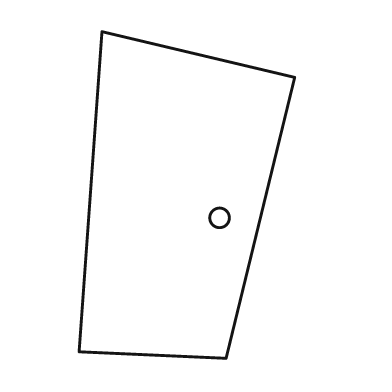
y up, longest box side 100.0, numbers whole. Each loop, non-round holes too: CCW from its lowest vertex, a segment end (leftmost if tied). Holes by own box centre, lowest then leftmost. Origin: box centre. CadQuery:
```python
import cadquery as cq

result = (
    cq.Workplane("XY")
    .moveTo(12.0, -50.0)
    .lineTo(33.0, 36.0)
    .lineTo(-26.0, 50.0)
    .lineTo(-33.0, -48.0)
    .close()
    .moveTo(10.0, -7.0)
    .circle(3.0)
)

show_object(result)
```